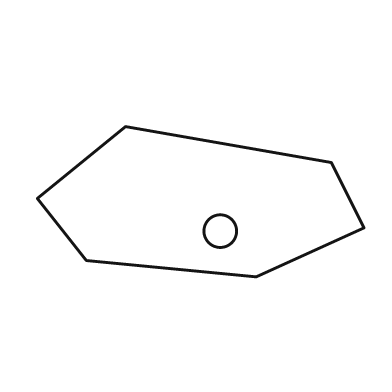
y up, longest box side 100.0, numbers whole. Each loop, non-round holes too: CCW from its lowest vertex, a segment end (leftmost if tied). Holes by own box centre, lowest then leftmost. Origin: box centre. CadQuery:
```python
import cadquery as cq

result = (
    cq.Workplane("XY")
    .moveTo(17.0, -23.0)
    .lineTo(50.0, -8.0)
    .lineTo(40.0, 12.0)
    .lineTo(-23.0, 23.0)
    .lineTo(-50.0, 1.0)
    .lineTo(-35.0, -18.0)
    .close()
    .moveTo(6.0, -9.0)
    .circle(5.0)
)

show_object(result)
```